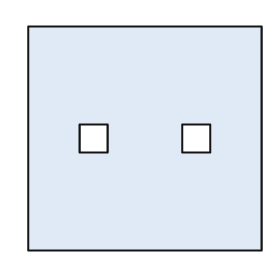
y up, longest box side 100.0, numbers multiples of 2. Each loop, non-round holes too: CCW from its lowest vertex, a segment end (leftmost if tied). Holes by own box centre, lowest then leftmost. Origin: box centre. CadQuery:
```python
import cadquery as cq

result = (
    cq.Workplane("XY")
    .moveTo(-50.0, -48.0)
    .lineTo(50.0, -48.0)
    .lineTo(50.0, 48.0)
    .lineTo(-50.0, 48.0)
    .close()
    .moveTo(-28.0, -6.0)
    .lineTo(-16.0, -6.0)
    .lineTo(-16.0, 6.0)
    .lineTo(-28.0, 6.0)
    .close()
    .moveTo(16.0, -6.0)
    .lineTo(28.0, -6.0)
    .lineTo(28.0, 6.0)
    .lineTo(16.0, 6.0)
    .close()
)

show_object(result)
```